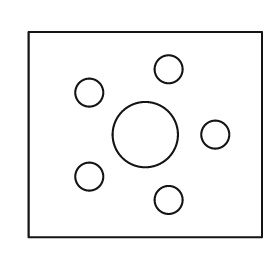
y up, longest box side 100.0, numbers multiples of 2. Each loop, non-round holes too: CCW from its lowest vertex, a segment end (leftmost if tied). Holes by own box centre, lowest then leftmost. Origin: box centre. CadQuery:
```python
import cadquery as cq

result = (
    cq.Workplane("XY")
    .moveTo(-50.0, -44.0)
    .lineTo(50.0, -44.0)
    .lineTo(50.0, 44.0)
    .lineTo(-50.0, 44.0)
    .close()
    .moveTo(10.0, -28.0)
    .circle(6.0)
    .moveTo(-24.0, -18.0)
    .circle(6.0)
    .moveTo(0.0, 0.0)
    .circle(14.0)
    .moveTo(30.0, 0.0)
    .circle(6.0)
    .moveTo(-24.0, 18.0)
    .circle(6.0)
    .moveTo(10.0, 28.0)
    .circle(6.0)
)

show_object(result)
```